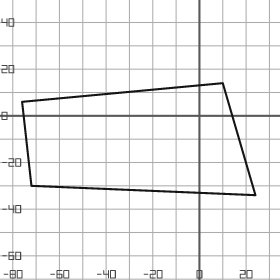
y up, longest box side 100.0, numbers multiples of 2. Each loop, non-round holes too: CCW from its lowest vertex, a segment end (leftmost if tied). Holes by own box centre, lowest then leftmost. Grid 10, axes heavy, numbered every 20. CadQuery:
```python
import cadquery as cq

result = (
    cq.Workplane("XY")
    .moveTo(24.0, -34.0)
    .lineTo(10.0, 14.0)
    .lineTo(-76.0, 6.0)
    .lineTo(-72.0, -30.0)
    .close()
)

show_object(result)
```